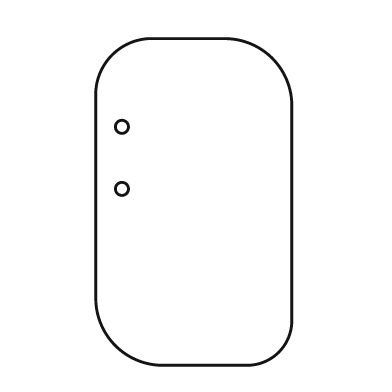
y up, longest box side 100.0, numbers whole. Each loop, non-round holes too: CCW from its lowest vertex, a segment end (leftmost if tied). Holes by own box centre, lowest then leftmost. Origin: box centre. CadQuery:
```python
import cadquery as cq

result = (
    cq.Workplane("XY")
    .moveTo(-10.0, -50.0)
    .lineTo(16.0, -50.0)
    .threePointArc((26.0, -46.0), (30.0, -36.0))
    .lineTo(30.0, 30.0)
    .threePointArc((24.0, 44.0), (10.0, 50.0))
    .lineTo(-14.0, 50.0)
    .threePointArc((-25.0, 45.0), (-30.0, 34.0))
    .lineTo(-30.0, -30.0)
    .threePointArc((-24.0, -44.0), (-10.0, -50.0))
    .close()
    .moveTo(-22.0, 4.0)
    .circle(2.0)
    .moveTo(-22.0, 23.0)
    .circle(2.0)
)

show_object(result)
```